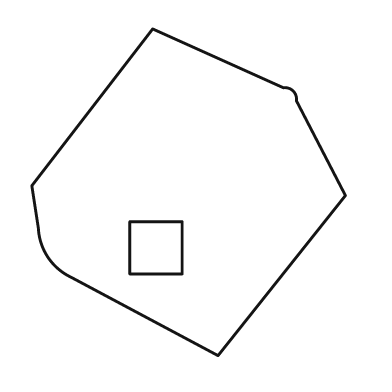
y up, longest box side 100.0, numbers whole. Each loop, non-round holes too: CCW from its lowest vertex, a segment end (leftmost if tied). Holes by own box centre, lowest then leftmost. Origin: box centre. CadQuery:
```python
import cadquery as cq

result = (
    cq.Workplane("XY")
    .moveTo(9.0, -50.0)
    .lineTo(48.0, -1.0)
    .lineTo(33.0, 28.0)
    .threePointArc((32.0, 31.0), (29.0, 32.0))
    .lineTo(-11.0, 50.0)
    .lineTo(-48.0, 2.0)
    .lineTo(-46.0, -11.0)
    .threePointArc((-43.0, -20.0), (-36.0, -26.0))
    .close()
    .moveTo(-18.0, -25.0)
    .lineTo(-2.0, -25.0)
    .lineTo(-2.0, -9.0)
    .lineTo(-18.0, -9.0)
    .close()
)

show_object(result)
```